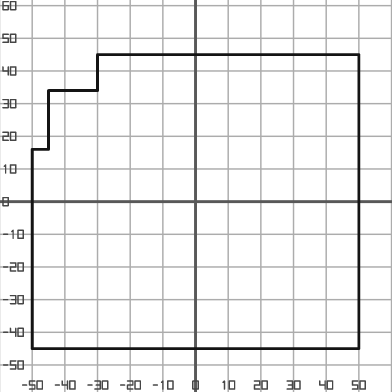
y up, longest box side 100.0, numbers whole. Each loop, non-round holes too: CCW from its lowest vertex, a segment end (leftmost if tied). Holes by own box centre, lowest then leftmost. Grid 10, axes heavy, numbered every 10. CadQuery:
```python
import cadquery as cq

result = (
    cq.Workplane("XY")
    .moveTo(-50.0, -45.0)
    .lineTo(50.0, -45.0)
    .lineTo(50.0, 45.0)
    .lineTo(-30.0, 45.0)
    .lineTo(-30.0, 34.0)
    .lineTo(-45.0, 34.0)
    .lineTo(-45.0, 16.0)
    .lineTo(-50.0, 16.0)
    .close()
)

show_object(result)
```